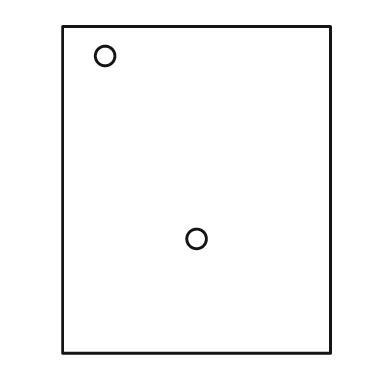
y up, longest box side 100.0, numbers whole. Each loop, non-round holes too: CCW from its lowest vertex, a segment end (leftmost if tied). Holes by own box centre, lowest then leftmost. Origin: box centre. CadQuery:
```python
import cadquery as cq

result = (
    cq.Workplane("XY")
    .moveTo(-41.0, -50.0)
    .lineTo(41.0, -50.0)
    .lineTo(41.0, 50.0)
    .lineTo(-41.0, 50.0)
    .close()
    .moveTo(0.0, -15.0)
    .circle(3.0)
    .moveTo(-28.0, 41.0)
    .circle(3.0)
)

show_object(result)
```